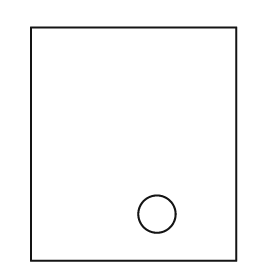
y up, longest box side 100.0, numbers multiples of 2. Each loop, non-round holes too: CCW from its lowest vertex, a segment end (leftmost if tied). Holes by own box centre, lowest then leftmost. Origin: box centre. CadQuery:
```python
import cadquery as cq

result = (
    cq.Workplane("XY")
    .moveTo(-44.0, -50.0)
    .lineTo(44.0, -50.0)
    .lineTo(44.0, 50.0)
    .lineTo(-44.0, 50.0)
    .close()
    .moveTo(10.0, -30.0)
    .circle(8.0)
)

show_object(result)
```